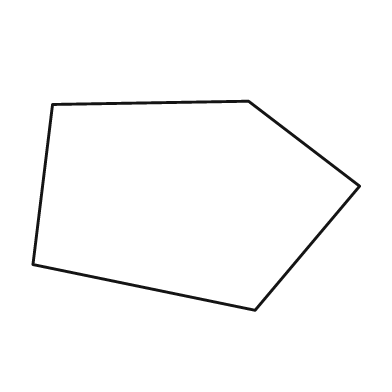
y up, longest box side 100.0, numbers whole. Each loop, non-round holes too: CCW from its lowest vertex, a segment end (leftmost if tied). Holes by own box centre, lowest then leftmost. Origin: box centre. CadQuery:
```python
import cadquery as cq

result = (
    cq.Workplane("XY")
    .moveTo(18.0, -32.0)
    .lineTo(50.0, 6.0)
    .lineTo(16.0, 32.0)
    .lineTo(-44.0, 31.0)
    .lineTo(-50.0, -18.0)
    .close()
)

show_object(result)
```